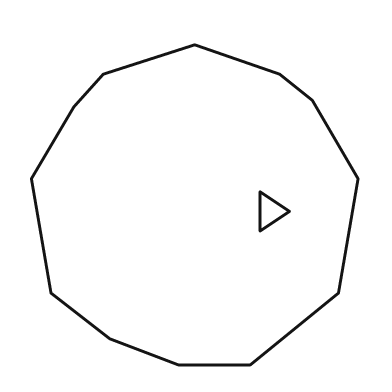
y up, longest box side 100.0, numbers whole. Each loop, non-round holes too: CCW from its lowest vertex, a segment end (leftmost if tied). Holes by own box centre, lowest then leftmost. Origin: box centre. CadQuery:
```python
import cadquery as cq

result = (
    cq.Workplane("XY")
    .moveTo(-5.0, -49.0)
    .lineTo(17.0, -49.0)
    .lineTo(44.0, -27.0)
    .lineTo(50.0, 8.0)
    .lineTo(36.0, 32.0)
    .lineTo(26.0, 40.0)
    .lineTo(0.0, 49.0)
    .lineTo(-28.0, 40.0)
    .lineTo(-37.0, 30.0)
    .lineTo(-50.0, 8.0)
    .lineTo(-44.0, -27.0)
    .lineTo(-26.0, -41.0)
    .close()
    .moveTo(20.0, -8.0)
    .lineTo(29.0, -2.0)
    .lineTo(20.0, 4.0)
    .close()
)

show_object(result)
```